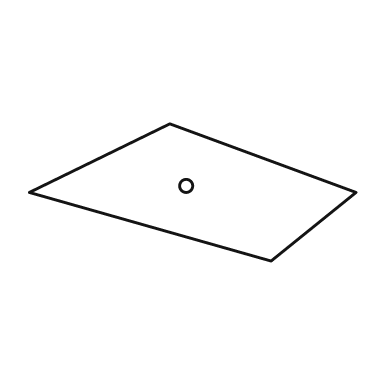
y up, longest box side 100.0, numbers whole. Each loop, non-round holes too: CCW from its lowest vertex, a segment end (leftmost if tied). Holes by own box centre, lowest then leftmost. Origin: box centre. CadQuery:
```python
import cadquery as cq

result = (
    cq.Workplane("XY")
    .moveTo(24.0, -21.0)
    .lineTo(50.0, 0.0)
    .lineTo(-7.0, 21.0)
    .lineTo(-50.0, 0.0)
    .close()
    .moveTo(-2.0, 2.0)
    .circle(2.0)
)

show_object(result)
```